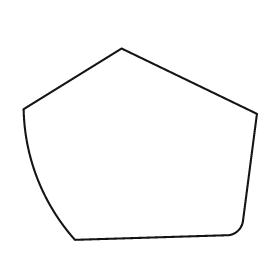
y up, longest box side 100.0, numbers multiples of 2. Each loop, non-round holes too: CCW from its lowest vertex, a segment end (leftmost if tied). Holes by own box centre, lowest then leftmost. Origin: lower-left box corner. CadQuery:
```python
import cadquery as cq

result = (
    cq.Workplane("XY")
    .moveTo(22.0, 0.0)
    .lineTo(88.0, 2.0)
    .threePointArc((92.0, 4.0), (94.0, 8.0))
    .lineTo(100.0, 54.0)
    .lineTo(42.0, 82.0)
    .lineTo(0.0, 56.0)
    .threePointArc((6.0, 26.0), (22.0, 0.0))
    .close()
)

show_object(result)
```